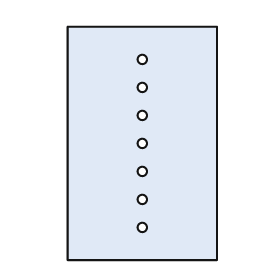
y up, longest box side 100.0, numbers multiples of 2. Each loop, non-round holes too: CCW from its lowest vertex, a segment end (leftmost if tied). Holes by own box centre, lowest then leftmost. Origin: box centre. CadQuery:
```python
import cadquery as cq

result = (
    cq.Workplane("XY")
    .moveTo(-32.0, -50.0)
    .lineTo(32.0, -50.0)
    .lineTo(32.0, 50.0)
    .lineTo(-32.0, 50.0)
    .close()
    .moveTo(0.0, -36.0)
    .circle(2.0)
    .moveTo(0.0, -24.0)
    .circle(2.0)
    .moveTo(0.0, -12.0)
    .circle(2.0)
    .moveTo(0.0, 0.0)
    .circle(2.0)
    .moveTo(0.0, 12.0)
    .circle(2.0)
    .moveTo(0.0, 24.0)
    .circle(2.0)
    .moveTo(0.0, 36.0)
    .circle(2.0)
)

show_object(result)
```